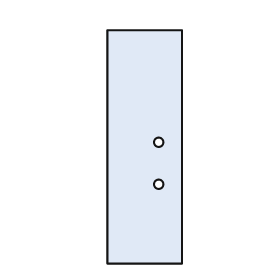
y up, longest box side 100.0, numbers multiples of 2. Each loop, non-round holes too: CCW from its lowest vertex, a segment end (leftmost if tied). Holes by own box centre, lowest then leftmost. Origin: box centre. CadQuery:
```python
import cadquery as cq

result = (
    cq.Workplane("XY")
    .moveTo(-16.0, -50.0)
    .lineTo(16.0, -50.0)
    .lineTo(16.0, 50.0)
    .lineTo(-16.0, 50.0)
    .close()
    .moveTo(6.0, -16.0)
    .circle(2.0)
    .moveTo(6.0, 2.0)
    .circle(2.0)
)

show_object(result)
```